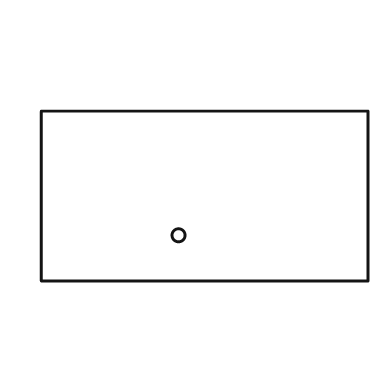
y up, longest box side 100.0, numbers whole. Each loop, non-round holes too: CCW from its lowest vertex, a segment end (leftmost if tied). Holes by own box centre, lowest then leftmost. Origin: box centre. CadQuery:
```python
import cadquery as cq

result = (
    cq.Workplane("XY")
    .moveTo(-50.0, -26.0)
    .lineTo(50.0, -26.0)
    .lineTo(50.0, 26.0)
    .lineTo(-50.0, 26.0)
    .close()
    .moveTo(-8.0, -12.0)
    .circle(2.0)
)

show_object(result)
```